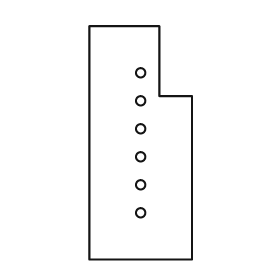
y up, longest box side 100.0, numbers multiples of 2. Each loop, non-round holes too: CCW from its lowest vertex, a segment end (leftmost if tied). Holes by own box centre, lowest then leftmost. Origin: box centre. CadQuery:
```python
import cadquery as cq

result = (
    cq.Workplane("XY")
    .moveTo(-22.0, -50.0)
    .lineTo(22.0, -50.0)
    .lineTo(22.0, 20.0)
    .lineTo(8.0, 20.0)
    .lineTo(8.0, 50.0)
    .lineTo(-22.0, 50.0)
    .close()
    .moveTo(0.0, -30.0)
    .circle(2.0)
    .moveTo(0.0, -18.0)
    .circle(2.0)
    .moveTo(0.0, -6.0)
    .circle(2.0)
    .moveTo(0.0, 6.0)
    .circle(2.0)
    .moveTo(0.0, 18.0)
    .circle(2.0)
    .moveTo(0.0, 30.0)
    .circle(2.0)
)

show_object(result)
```